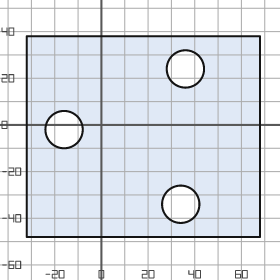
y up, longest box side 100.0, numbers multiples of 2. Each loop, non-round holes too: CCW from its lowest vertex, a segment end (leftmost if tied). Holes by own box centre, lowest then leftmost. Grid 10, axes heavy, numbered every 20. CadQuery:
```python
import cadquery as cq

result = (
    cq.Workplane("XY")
    .moveTo(-32.0, -48.0)
    .lineTo(68.0, -48.0)
    .lineTo(68.0, 38.0)
    .lineTo(-32.0, 38.0)
    .close()
    .moveTo(34.0, -34.0)
    .circle(8.0)
    .moveTo(-16.0, -2.0)
    .circle(8.0)
    .moveTo(36.0, 24.0)
    .circle(8.0)
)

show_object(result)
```